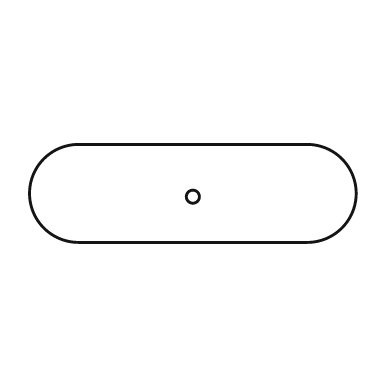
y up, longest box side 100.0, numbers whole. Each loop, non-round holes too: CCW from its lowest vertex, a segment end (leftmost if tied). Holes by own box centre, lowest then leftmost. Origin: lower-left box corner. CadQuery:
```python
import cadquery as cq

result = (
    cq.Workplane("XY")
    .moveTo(15.0, 0.0)
    .lineTo(85.0, 0.0)
    .threePointArc((100.0, 15.0), (85.0, 30.0))
    .lineTo(15.0, 30.0)
    .threePointArc((0.0, 15.0), (15.0, 0.0))
    .close()
    .moveTo(50.0, 14.0)
    .circle(2.0)
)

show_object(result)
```